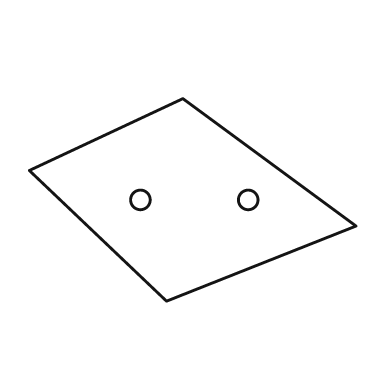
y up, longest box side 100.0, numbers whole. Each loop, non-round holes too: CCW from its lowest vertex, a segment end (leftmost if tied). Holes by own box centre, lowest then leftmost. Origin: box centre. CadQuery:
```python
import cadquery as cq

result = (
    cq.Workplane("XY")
    .moveTo(-8.0, -31.0)
    .lineTo(50.0, -8.0)
    .lineTo(-3.0, 31.0)
    .lineTo(-50.0, 9.0)
    .close()
    .moveTo(-16.0, 0.0)
    .circle(3.0)
    .moveTo(17.0, 0.0)
    .circle(3.0)
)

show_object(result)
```